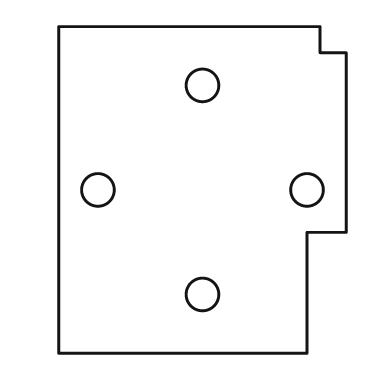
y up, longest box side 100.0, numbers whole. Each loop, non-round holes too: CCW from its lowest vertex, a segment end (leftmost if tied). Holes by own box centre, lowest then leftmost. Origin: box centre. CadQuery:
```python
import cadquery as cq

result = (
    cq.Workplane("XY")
    .moveTo(-44.0, -50.0)
    .lineTo(32.0, -50.0)
    .lineTo(32.0, -13.0)
    .lineTo(44.0, -13.0)
    .lineTo(44.0, 42.0)
    .lineTo(36.0, 42.0)
    .lineTo(36.0, 50.0)
    .lineTo(-44.0, 50.0)
    .close()
    .moveTo(0.0, -32.0)
    .circle(5.0)
    .moveTo(-32.0, 0.0)
    .circle(5.0)
    .moveTo(32.0, 0.0)
    .circle(5.0)
    .moveTo(0.0, 32.0)
    .circle(5.0)
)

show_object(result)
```